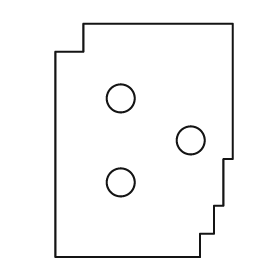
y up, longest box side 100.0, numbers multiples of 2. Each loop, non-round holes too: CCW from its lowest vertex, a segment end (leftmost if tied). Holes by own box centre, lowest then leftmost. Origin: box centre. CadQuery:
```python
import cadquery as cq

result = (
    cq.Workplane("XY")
    .moveTo(-38.0, -50.0)
    .lineTo(24.0, -50.0)
    .lineTo(24.0, -40.0)
    .lineTo(30.0, -40.0)
    .lineTo(30.0, -28.0)
    .lineTo(34.0, -28.0)
    .lineTo(34.0, -8.0)
    .lineTo(38.0, -8.0)
    .lineTo(38.0, 50.0)
    .lineTo(-26.0, 50.0)
    .lineTo(-26.0, 38.0)
    .lineTo(-38.0, 38.0)
    .close()
    .moveTo(-10.0, -18.0)
    .circle(6.0)
    .moveTo(20.0, 0.0)
    .circle(6.0)
    .moveTo(-10.0, 18.0)
    .circle(6.0)
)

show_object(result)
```